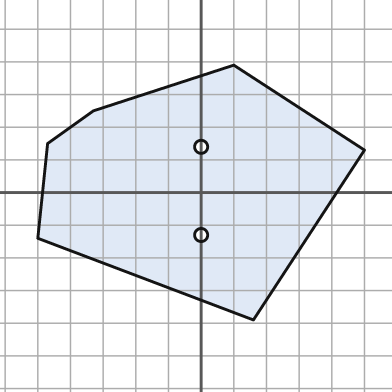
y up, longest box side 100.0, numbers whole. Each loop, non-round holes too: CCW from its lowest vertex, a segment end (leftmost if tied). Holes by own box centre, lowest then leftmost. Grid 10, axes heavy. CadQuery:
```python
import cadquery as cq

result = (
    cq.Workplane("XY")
    .moveTo(16.0, -39.0)
    .lineTo(50.0, 13.0)
    .lineTo(10.0, 39.0)
    .lineTo(-33.0, 25.0)
    .lineTo(-47.0, 15.0)
    .lineTo(-50.0, -14.0)
    .close()
    .moveTo(0.0, -13.0)
    .circle(2.0)
    .moveTo(0.0, 14.0)
    .circle(2.0)
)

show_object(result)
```